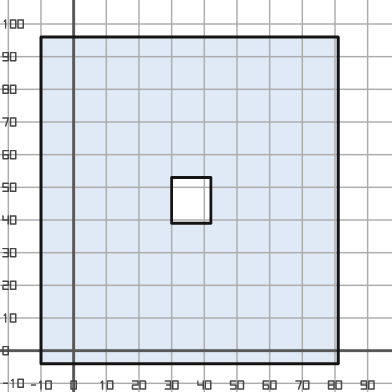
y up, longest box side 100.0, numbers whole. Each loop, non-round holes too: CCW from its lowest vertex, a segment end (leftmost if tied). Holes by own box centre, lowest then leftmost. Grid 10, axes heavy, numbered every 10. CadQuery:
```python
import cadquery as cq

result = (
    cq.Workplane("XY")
    .moveTo(-10.0, -4.0)
    .lineTo(81.0, -4.0)
    .lineTo(81.0, 96.0)
    .lineTo(-10.0, 96.0)
    .close()
    .moveTo(30.0, 39.0)
    .lineTo(42.0, 39.0)
    .lineTo(42.0, 53.0)
    .lineTo(30.0, 53.0)
    .close()
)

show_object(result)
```